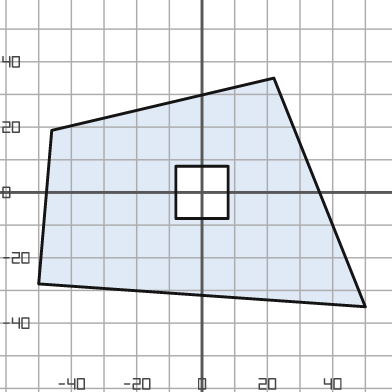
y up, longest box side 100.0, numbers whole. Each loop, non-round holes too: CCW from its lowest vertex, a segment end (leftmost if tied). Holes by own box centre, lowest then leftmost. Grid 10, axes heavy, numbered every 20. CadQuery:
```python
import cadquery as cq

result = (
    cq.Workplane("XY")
    .moveTo(50.0, -35.0)
    .lineTo(22.0, 35.0)
    .lineTo(-46.0, 19.0)
    .lineTo(-50.0, -28.0)
    .close()
    .moveTo(-8.0, -8.0)
    .lineTo(8.0, -8.0)
    .lineTo(8.0, 8.0)
    .lineTo(-8.0, 8.0)
    .close()
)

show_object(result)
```